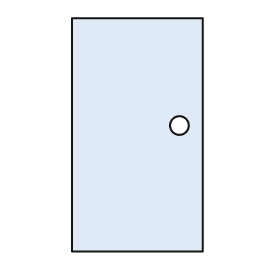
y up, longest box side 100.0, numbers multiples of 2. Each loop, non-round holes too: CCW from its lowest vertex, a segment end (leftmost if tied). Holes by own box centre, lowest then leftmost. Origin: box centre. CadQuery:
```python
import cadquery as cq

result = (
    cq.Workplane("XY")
    .moveTo(-28.0, -50.0)
    .lineTo(28.0, -50.0)
    .lineTo(28.0, 50.0)
    .lineTo(-28.0, 50.0)
    .close()
    .moveTo(18.0, 4.0)
    .circle(4.0)
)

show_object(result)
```